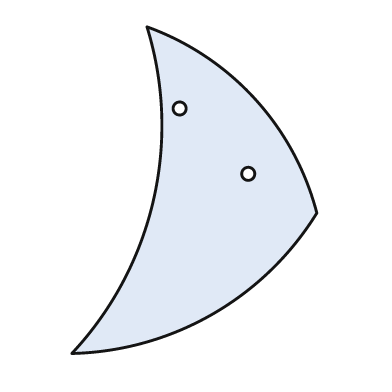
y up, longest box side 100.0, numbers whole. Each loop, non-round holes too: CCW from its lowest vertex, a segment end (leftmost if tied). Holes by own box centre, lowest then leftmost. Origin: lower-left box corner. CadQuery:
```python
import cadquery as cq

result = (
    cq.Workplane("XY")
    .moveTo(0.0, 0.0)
    .threePointArc((43.0, 12.0), (75.0, 43.0))
    .threePointArc((56.0, 78.0), (23.0, 100.0))
    .threePointArc((25.0, 47.0), (0.0, 0.0))
    .close()
    .moveTo(54.0, 55.0)
    .circle(2.0)
    .moveTo(33.0, 75.0)
    .circle(2.0)
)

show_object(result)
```